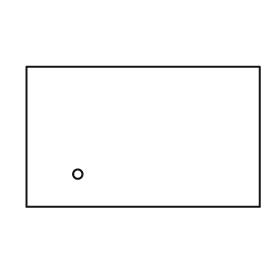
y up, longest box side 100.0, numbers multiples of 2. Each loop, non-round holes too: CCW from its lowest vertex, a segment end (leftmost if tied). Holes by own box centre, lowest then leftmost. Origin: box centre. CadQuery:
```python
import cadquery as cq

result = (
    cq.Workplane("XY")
    .moveTo(-50.0, -30.0)
    .lineTo(50.0, -30.0)
    .lineTo(50.0, 30.0)
    .lineTo(-50.0, 30.0)
    .close()
    .moveTo(-28.0, -16.0)
    .circle(2.0)
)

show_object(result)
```